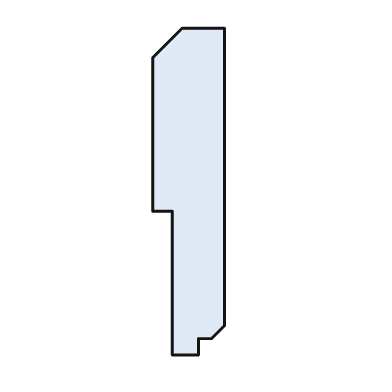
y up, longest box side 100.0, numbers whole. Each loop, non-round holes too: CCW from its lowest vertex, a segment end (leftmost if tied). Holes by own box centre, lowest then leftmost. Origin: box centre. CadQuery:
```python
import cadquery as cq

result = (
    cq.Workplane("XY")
    .moveTo(-5.0, -50.0)
    .lineTo(3.0, -50.0)
    .lineTo(3.0, -45.0)
    .lineTo(7.0, -45.0)
    .lineTo(11.0, -41.0)
    .lineTo(11.0, 50.0)
    .lineTo(-2.0, 50.0)
    .lineTo(-11.0, 41.0)
    .lineTo(-11.0, -6.0)
    .lineTo(-5.0, -6.0)
    .close()
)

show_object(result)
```